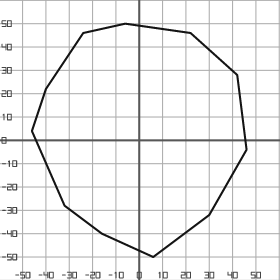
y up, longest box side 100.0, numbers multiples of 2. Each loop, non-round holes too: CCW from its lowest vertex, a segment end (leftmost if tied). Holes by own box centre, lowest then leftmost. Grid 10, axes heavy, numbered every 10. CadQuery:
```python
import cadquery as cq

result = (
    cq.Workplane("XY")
    .moveTo(6.0, -50.0)
    .lineTo(30.0, -32.0)
    .lineTo(46.0, -4.0)
    .lineTo(42.0, 28.0)
    .lineTo(22.0, 46.0)
    .lineTo(-6.0, 50.0)
    .lineTo(-24.0, 46.0)
    .lineTo(-40.0, 22.0)
    .lineTo(-46.0, 4.0)
    .lineTo(-32.0, -28.0)
    .lineTo(-16.0, -40.0)
    .close()
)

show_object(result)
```